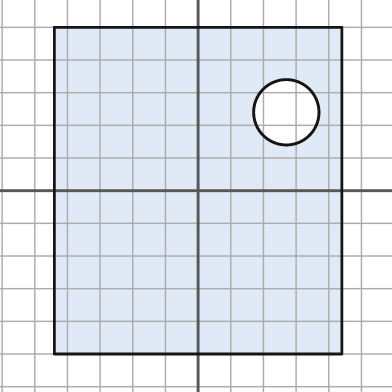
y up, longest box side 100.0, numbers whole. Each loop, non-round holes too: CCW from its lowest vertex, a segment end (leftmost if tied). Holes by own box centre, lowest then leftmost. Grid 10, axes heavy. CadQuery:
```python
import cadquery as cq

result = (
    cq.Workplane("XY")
    .moveTo(-44.0, -50.0)
    .lineTo(44.0, -50.0)
    .lineTo(44.0, 50.0)
    .lineTo(-44.0, 50.0)
    .close()
    .moveTo(27.0, 24.0)
    .circle(10.0)
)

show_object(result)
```